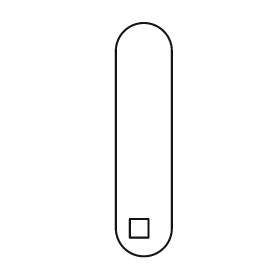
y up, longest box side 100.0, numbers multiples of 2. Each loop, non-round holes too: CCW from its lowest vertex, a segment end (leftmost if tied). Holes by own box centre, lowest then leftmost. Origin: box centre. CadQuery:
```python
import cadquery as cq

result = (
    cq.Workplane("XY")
    .moveTo(-12.0, -38.0)
    .threePointArc((0.0, -50.0), (12.0, -38.0))
    .lineTo(12.0, 38.0)
    .threePointArc((0.0, 50.0), (-12.0, 38.0))
    .close()
    .moveTo(-6.0, -42.0)
    .lineTo(2.0, -42.0)
    .lineTo(2.0, -34.0)
    .lineTo(-6.0, -34.0)
    .close()
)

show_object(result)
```